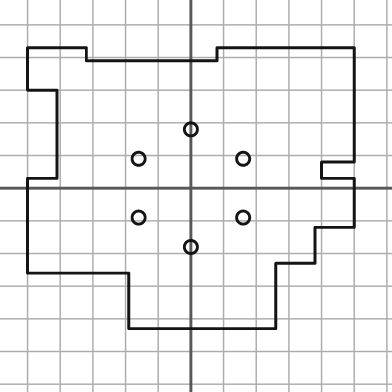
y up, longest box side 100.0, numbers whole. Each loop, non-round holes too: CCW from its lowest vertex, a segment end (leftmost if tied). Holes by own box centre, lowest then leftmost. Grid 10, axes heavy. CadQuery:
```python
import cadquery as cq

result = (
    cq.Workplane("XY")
    .moveTo(-19.0, -43.0)
    .lineTo(26.0, -43.0)
    .lineTo(26.0, -23.0)
    .lineTo(38.0, -23.0)
    .lineTo(38.0, -12.0)
    .lineTo(50.0, -12.0)
    .lineTo(50.0, 3.0)
    .lineTo(40.0, 3.0)
    .lineTo(40.0, 8.0)
    .lineTo(50.0, 8.0)
    .lineTo(50.0, 43.0)
    .lineTo(8.0, 43.0)
    .lineTo(8.0, 39.0)
    .lineTo(-32.0, 39.0)
    .lineTo(-32.0, 43.0)
    .lineTo(-50.0, 43.0)
    .lineTo(-50.0, 30.0)
    .lineTo(-41.0, 30.0)
    .lineTo(-41.0, 3.0)
    .lineTo(-50.0, 3.0)
    .lineTo(-50.0, -26.0)
    .lineTo(-19.0, -26.0)
    .close()
    .moveTo(0.0, -18.0)
    .circle(2.0)
    .moveTo(-16.0, -9.0)
    .circle(2.0)
    .moveTo(16.0, -9.0)
    .circle(2.0)
    .moveTo(-16.0, 9.0)
    .circle(2.0)
    .moveTo(16.0, 9.0)
    .circle(2.0)
    .moveTo(0.0, 18.0)
    .circle(2.0)
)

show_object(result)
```